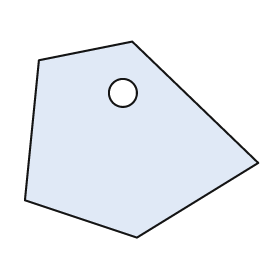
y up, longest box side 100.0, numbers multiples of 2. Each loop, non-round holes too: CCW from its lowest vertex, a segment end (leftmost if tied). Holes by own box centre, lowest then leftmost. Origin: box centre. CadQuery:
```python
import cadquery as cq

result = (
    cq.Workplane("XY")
    .moveTo(-2.0, -42.0)
    .lineTo(50.0, -10.0)
    .lineTo(-4.0, 42.0)
    .lineTo(-44.0, 34.0)
    .lineTo(-50.0, -26.0)
    .close()
    .moveTo(-8.0, 20.0)
    .circle(6.0)
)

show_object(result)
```